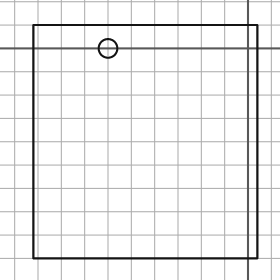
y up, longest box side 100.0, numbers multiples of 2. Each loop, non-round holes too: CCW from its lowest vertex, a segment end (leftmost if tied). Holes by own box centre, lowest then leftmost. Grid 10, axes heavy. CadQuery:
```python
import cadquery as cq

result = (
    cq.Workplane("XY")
    .moveTo(-92.0, -90.0)
    .lineTo(4.0, -90.0)
    .lineTo(4.0, 10.0)
    .lineTo(-92.0, 10.0)
    .close()
    .moveTo(-60.0, 0.0)
    .circle(4.0)
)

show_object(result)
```